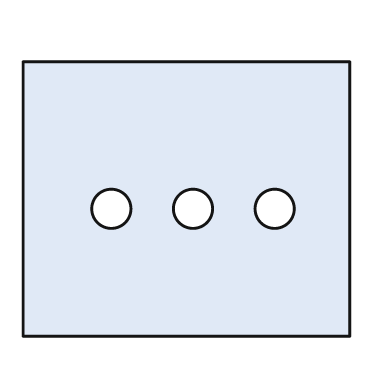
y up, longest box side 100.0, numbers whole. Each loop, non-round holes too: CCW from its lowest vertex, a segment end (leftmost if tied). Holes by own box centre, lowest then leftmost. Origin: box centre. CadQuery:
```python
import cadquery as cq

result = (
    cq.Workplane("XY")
    .moveTo(-50.0, -42.0)
    .lineTo(50.0, -42.0)
    .lineTo(50.0, 42.0)
    .lineTo(-50.0, 42.0)
    .close()
    .moveTo(-23.0, -3.0)
    .circle(6.0)
    .moveTo(2.0, -3.0)
    .circle(6.0)
    .moveTo(27.0, -3.0)
    .circle(6.0)
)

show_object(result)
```